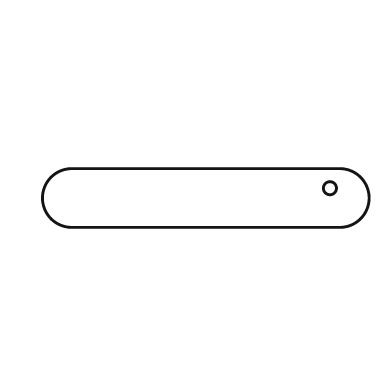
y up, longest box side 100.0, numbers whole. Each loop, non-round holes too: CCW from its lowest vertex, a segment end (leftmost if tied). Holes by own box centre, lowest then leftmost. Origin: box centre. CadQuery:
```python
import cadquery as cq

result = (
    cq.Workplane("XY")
    .moveTo(-41.0, -9.0)
    .lineTo(41.0, -9.0)
    .threePointArc((50.0, 0.0), (41.0, 9.0))
    .lineTo(-41.0, 9.0)
    .threePointArc((-50.0, 0.0), (-41.0, -9.0))
    .close()
    .moveTo(38.0, 3.0)
    .circle(2.0)
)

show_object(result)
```